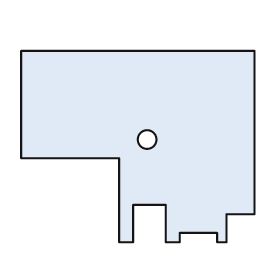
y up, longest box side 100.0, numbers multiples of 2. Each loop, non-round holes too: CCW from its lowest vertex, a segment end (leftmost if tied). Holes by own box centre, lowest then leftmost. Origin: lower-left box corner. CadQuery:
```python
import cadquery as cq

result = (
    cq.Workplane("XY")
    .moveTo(42.0, 0.0)
    .lineTo(48.0, 0.0)
    .lineTo(48.0, 16.0)
    .lineTo(62.0, 16.0)
    .lineTo(62.0, 0.0)
    .lineTo(68.0, 0.0)
    .lineTo(68.0, 4.0)
    .lineTo(84.0, 4.0)
    .lineTo(84.0, 0.0)
    .lineTo(88.0, 0.0)
    .lineTo(88.0, 12.0)
    .lineTo(100.0, 12.0)
    .lineTo(100.0, 82.0)
    .lineTo(0.0, 82.0)
    .lineTo(0.0, 36.0)
    .lineTo(42.0, 36.0)
    .close()
    .moveTo(54.0, 44.0)
    .circle(4.0)
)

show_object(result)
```